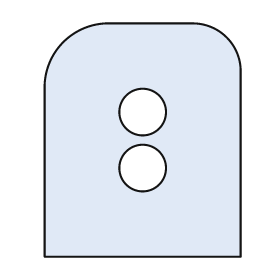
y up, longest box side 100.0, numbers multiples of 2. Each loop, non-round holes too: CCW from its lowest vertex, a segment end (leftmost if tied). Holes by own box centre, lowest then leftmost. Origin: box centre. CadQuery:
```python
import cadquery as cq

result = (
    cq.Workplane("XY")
    .moveTo(-42.0, -50.0)
    .lineTo(42.0, -50.0)
    .lineTo(42.0, 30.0)
    .threePointArc((36.0, 44.0), (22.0, 50.0))
    .lineTo(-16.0, 50.0)
    .threePointArc((-34.0, 42.0), (-42.0, 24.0))
    .close()
    .moveTo(0.0, -12.0)
    .circle(10.0)
    .moveTo(0.0, 12.0)
    .circle(10.0)
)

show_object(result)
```